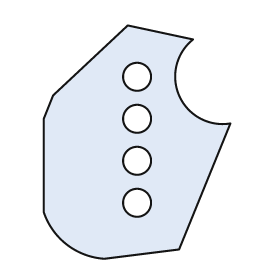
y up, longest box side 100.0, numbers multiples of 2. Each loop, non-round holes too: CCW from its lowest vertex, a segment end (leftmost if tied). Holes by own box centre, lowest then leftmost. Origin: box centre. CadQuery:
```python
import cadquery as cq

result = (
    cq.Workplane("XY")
    .moveTo(-14.0, -50.0)
    .lineTo(18.0, -46.0)
    .lineTo(40.0, 8.0)
    .threePointArc((18.0, 20.0), (24.0, 44.0))
    .lineTo(-4.0, 50.0)
    .lineTo(-36.0, 20.0)
    .lineTo(-40.0, 10.0)
    .lineTo(-40.0, -30.0)
    .threePointArc((-30.0, -44.0), (-14.0, -50.0))
    .close()
    .moveTo(0.0, -26.0)
    .circle(6.0)
    .moveTo(0.0, -8.0)
    .circle(6.0)
    .moveTo(0.0, 10.0)
    .circle(6.0)
    .moveTo(0.0, 28.0)
    .circle(6.0)
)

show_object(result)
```